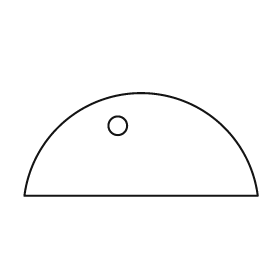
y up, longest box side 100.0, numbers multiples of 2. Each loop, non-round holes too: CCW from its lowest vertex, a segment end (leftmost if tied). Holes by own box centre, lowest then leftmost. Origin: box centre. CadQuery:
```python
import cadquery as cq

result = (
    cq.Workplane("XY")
    .moveTo(-50.0, -22.0)
    .lineTo(50.0, -22.0)
    .threePointArc((0.0, 22.0), (-50.0, -22.0))
    .close()
    .moveTo(-10.0, 8.0)
    .circle(4.0)
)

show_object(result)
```